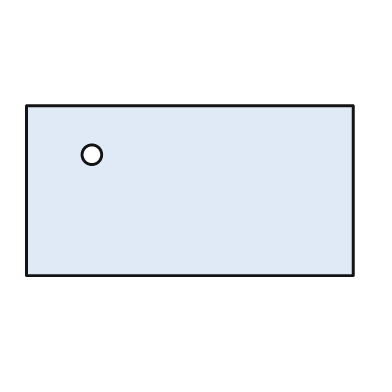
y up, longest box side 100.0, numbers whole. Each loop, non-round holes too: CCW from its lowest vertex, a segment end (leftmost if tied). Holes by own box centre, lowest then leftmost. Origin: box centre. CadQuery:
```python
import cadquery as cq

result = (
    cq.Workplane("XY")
    .moveTo(-50.0, -26.0)
    .lineTo(50.0, -26.0)
    .lineTo(50.0, 26.0)
    .lineTo(-50.0, 26.0)
    .close()
    .moveTo(-30.0, 11.0)
    .circle(3.0)
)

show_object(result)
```